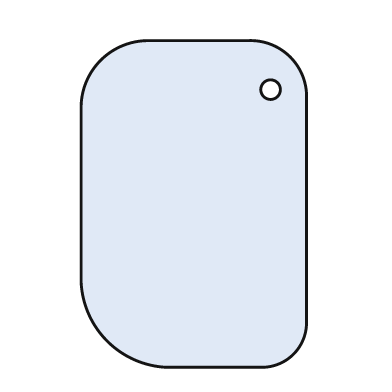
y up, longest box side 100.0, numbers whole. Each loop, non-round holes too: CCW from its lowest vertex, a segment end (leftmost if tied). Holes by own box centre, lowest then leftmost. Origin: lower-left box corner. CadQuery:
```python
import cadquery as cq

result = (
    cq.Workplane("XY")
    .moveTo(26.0, 0.0)
    .lineTo(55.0, 0.0)
    .threePointArc((65.0, 4.0), (69.0, 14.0))
    .lineTo(69.0, 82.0)
    .threePointArc((64.0, 95.0), (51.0, 100.0))
    .lineTo(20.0, 100.0)
    .threePointArc((6.0, 94.0), (0.0, 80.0))
    .lineTo(0.0, 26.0)
    .threePointArc((8.0, 8.0), (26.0, 0.0))
    .close()
    .moveTo(58.0, 85.0)
    .circle(3.0)
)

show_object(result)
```